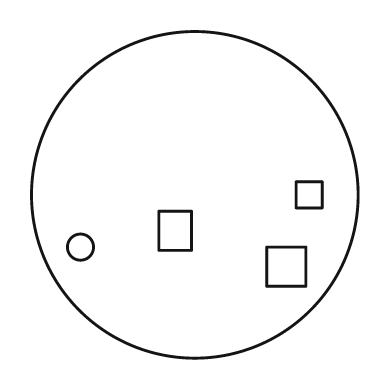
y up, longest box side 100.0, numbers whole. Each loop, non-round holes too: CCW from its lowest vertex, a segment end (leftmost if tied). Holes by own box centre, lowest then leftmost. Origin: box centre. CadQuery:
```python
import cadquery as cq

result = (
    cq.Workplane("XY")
    .moveTo(0.0, 0.0)
    .circle(50.0)
    .moveTo(22.0, -28.0)
    .lineTo(34.0, -28.0)
    .lineTo(34.0, -16.0)
    .lineTo(22.0, -16.0)
    .close()
    .moveTo(-35.0, -16.0)
    .circle(4.0)
    .moveTo(-11.0, -17.0)
    .lineTo(-1.0, -17.0)
    .lineTo(-1.0, -5.0)
    .lineTo(-11.0, -5.0)
    .close()
    .moveTo(31.0, -4.0)
    .lineTo(39.0, -4.0)
    .lineTo(39.0, 4.0)
    .lineTo(31.0, 4.0)
    .close()
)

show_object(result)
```